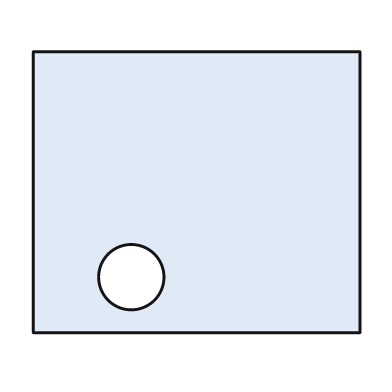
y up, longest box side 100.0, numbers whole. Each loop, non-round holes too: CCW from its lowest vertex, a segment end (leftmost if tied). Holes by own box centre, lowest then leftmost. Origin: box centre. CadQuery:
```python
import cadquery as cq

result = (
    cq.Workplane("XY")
    .moveTo(-50.0, -43.0)
    .lineTo(50.0, -43.0)
    .lineTo(50.0, 43.0)
    .lineTo(-50.0, 43.0)
    .close()
    .moveTo(-20.0, -26.0)
    .circle(10.0)
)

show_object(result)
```